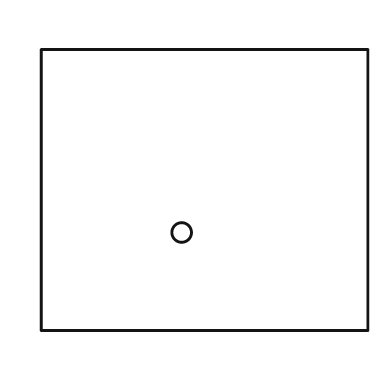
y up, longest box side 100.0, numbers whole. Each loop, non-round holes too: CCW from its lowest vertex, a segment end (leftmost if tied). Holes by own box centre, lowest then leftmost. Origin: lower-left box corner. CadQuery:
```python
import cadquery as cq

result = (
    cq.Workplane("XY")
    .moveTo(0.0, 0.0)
    .lineTo(100.0, 0.0)
    .lineTo(100.0, 86.0)
    .lineTo(0.0, 86.0)
    .close()
    .moveTo(43.0, 30.0)
    .circle(3.0)
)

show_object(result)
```